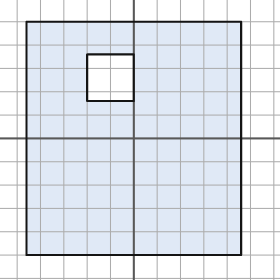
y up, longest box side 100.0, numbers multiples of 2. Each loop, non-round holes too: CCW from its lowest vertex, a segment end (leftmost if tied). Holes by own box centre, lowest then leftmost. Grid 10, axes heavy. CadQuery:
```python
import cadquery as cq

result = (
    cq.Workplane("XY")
    .moveTo(-46.0, -50.0)
    .lineTo(46.0, -50.0)
    .lineTo(46.0, 50.0)
    .lineTo(-46.0, 50.0)
    .close()
    .moveTo(-20.0, 16.0)
    .lineTo(0.0, 16.0)
    .lineTo(0.0, 36.0)
    .lineTo(-20.0, 36.0)
    .close()
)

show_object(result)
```